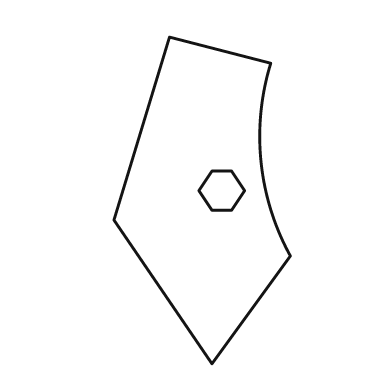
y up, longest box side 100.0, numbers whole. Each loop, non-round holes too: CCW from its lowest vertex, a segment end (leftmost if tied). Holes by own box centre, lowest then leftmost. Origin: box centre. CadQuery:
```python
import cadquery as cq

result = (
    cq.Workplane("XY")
    .moveTo(3.0, -50.0)
    .lineTo(27.0, -17.0)
    .threePointArc((18.0, 12.0), (21.0, 42.0))
    .lineTo(-10.0, 50.0)
    .lineTo(-27.0, -6.0)
    .close()
    .moveTo(3.0, -3.0)
    .lineTo(9.0, -3.0)
    .lineTo(13.0, 3.0)
    .lineTo(9.0, 9.0)
    .lineTo(3.0, 9.0)
    .lineTo(-1.0, 3.0)
    .close()
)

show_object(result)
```